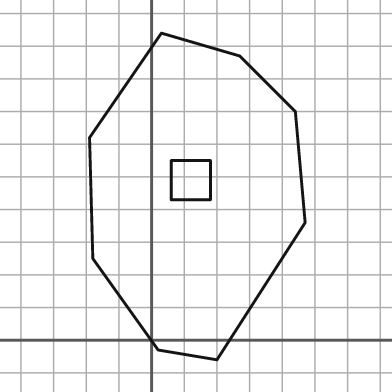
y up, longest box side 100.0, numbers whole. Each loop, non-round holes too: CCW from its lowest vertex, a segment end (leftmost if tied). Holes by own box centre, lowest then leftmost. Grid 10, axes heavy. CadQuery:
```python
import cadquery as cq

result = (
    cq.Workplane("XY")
    .moveTo(20.0, -6.0)
    .lineTo(47.0, 36.0)
    .lineTo(44.0, 70.0)
    .lineTo(27.0, 87.0)
    .lineTo(3.0, 94.0)
    .lineTo(-19.0, 62.0)
    .lineTo(-18.0, 25.0)
    .lineTo(2.0, -3.0)
    .close()
    .moveTo(6.0, 43.0)
    .lineTo(18.0, 43.0)
    .lineTo(18.0, 55.0)
    .lineTo(6.0, 55.0)
    .close()
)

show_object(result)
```